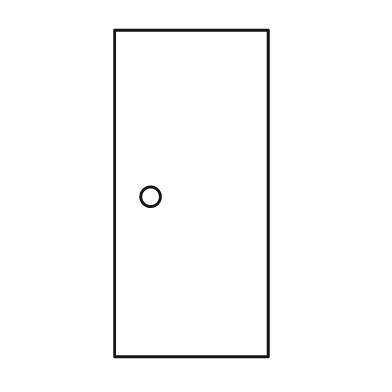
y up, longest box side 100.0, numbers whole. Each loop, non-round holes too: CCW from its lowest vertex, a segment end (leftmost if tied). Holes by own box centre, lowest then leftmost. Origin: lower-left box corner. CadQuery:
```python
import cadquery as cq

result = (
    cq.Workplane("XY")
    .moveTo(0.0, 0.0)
    .lineTo(47.0, 0.0)
    .lineTo(47.0, 100.0)
    .lineTo(0.0, 100.0)
    .close()
    .moveTo(11.0, 49.0)
    .circle(3.0)
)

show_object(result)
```